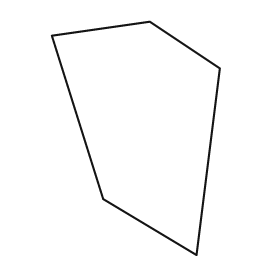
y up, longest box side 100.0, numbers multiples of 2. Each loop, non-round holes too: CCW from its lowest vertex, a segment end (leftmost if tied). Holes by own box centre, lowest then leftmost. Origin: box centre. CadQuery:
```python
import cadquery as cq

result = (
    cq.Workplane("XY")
    .moveTo(26.0, -50.0)
    .lineTo(36.0, 30.0)
    .lineTo(6.0, 50.0)
    .lineTo(-36.0, 44.0)
    .lineTo(-14.0, -26.0)
    .close()
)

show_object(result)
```